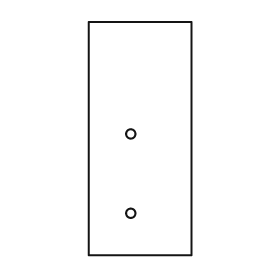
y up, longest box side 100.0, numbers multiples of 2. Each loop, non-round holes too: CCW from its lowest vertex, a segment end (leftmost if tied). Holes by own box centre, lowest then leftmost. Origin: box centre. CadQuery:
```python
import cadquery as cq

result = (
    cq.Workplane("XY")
    .moveTo(-22.0, -50.0)
    .lineTo(22.0, -50.0)
    .lineTo(22.0, 50.0)
    .lineTo(-22.0, 50.0)
    .close()
    .moveTo(-4.0, -32.0)
    .circle(2.0)
    .moveTo(-4.0, 2.0)
    .circle(2.0)
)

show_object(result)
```